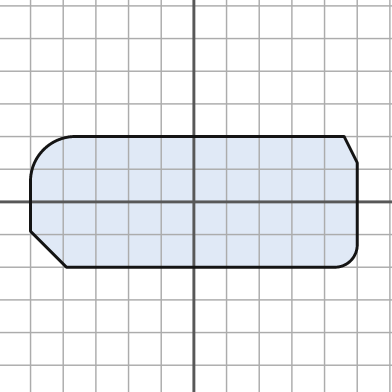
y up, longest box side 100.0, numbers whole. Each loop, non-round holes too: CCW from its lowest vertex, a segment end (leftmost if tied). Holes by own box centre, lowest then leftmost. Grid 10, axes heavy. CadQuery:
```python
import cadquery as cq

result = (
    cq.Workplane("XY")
    .moveTo(-39.0, -20.0)
    .lineTo(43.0, -20.0)
    .threePointArc((48.0, -18.0), (50.0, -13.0))
    .lineTo(50.0, 12.0)
    .lineTo(46.0, 20.0)
    .lineTo(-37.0, 20.0)
    .threePointArc((-46.0, 16.0), (-50.0, 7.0))
    .lineTo(-50.0, -9.0)
    .close()
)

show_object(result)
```